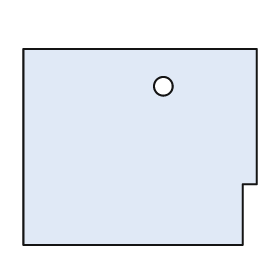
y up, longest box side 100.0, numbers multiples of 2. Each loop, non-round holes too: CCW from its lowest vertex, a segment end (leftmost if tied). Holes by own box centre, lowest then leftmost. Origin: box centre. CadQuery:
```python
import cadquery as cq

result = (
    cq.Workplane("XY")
    .moveTo(-50.0, -42.0)
    .lineTo(44.0, -42.0)
    .lineTo(44.0, -16.0)
    .lineTo(50.0, -16.0)
    .lineTo(50.0, 42.0)
    .lineTo(-50.0, 42.0)
    .close()
    .moveTo(10.0, 26.0)
    .circle(4.0)
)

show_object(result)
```